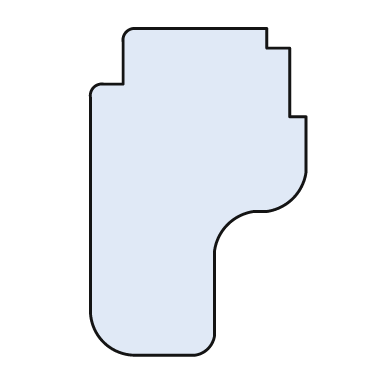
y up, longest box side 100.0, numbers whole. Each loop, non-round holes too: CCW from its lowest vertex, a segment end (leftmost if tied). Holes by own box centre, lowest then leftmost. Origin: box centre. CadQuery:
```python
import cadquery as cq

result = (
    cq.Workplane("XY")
    .moveTo(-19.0, -50.0)
    .lineTo(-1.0, -50.0)
    .threePointArc((3.0, -48.0), (5.0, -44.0))
    .lineTo(5.0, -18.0)
    .threePointArc((9.0, -10.0), (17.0, -6.0))
    .lineTo(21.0, -6.0)
    .threePointArc((29.0, -2.0), (33.0, 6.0))
    .lineTo(33.0, 23.0)
    .lineTo(28.0, 23.0)
    .lineTo(28.0, 44.0)
    .lineTo(21.0, 44.0)
    .lineTo(21.0, 50.0)
    .lineTo(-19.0, 50.0)
    .threePointArc((-22.0, 49.0), (-23.0, 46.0))
    .lineTo(-23.0, 33.0)
    .lineTo(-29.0, 33.0)
    .threePointArc((-32.0, 32.0), (-33.0, 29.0))
    .lineTo(-33.0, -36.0)
    .threePointArc((-29.0, -46.0), (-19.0, -50.0))
    .close()
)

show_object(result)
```